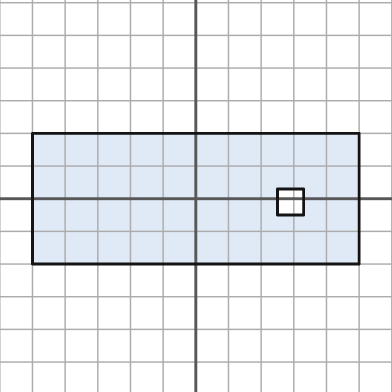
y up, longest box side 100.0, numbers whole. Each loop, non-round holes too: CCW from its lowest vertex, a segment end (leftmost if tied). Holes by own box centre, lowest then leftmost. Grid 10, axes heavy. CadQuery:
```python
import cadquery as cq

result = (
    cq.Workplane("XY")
    .moveTo(-50.0, -20.0)
    .lineTo(50.0, -20.0)
    .lineTo(50.0, 20.0)
    .lineTo(-50.0, 20.0)
    .close()
    .moveTo(25.0, -5.0)
    .lineTo(33.0, -5.0)
    .lineTo(33.0, 3.0)
    .lineTo(25.0, 3.0)
    .close()
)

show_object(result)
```